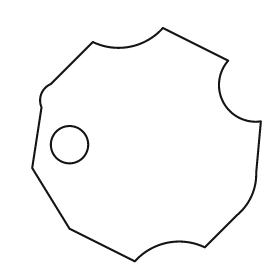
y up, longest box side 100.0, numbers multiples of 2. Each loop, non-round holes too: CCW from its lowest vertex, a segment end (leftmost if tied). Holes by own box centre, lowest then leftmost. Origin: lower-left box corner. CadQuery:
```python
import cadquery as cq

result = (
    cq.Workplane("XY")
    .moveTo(44.0, 0.0)
    .threePointArc((58.0, 8.0), (74.0, 6.0))
    .lineTo(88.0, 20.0)
    .threePointArc((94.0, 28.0), (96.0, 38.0))
    .lineTo(98.0, 60.0)
    .threePointArc((82.0, 68.0), (84.0, 86.0))
    .lineTo(56.0, 100.0)
    .threePointArc((42.0, 92.0), (26.0, 94.0))
    .lineTo(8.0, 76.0)
    .threePointArc((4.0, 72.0), (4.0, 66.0))
    .lineTo(0.0, 40.0)
    .lineTo(16.0, 14.0)
    .close()
    .moveTo(16.0, 50.0)
    .circle(8.0)
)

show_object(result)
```